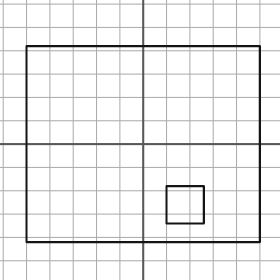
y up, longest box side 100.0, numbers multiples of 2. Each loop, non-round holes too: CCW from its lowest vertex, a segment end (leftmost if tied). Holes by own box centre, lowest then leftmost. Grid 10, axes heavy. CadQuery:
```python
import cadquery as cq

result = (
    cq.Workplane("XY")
    .moveTo(-50.0, -42.0)
    .lineTo(50.0, -42.0)
    .lineTo(50.0, 42.0)
    .lineTo(-50.0, 42.0)
    .close()
    .moveTo(10.0, -34.0)
    .lineTo(26.0, -34.0)
    .lineTo(26.0, -18.0)
    .lineTo(10.0, -18.0)
    .close()
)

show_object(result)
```